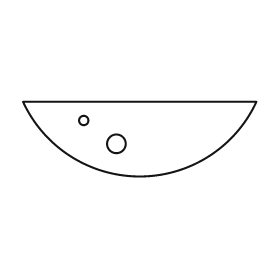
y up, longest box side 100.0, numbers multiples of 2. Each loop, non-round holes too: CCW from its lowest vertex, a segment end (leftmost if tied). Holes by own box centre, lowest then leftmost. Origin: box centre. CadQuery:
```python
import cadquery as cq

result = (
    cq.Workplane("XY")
    .moveTo(-50.0, 16.0)
    .threePointArc((0.0, -16.0), (50.0, 16.0))
    .close()
    .moveTo(-10.0, -2.0)
    .circle(4.0)
    .moveTo(-24.0, 8.0)
    .circle(2.0)
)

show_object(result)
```